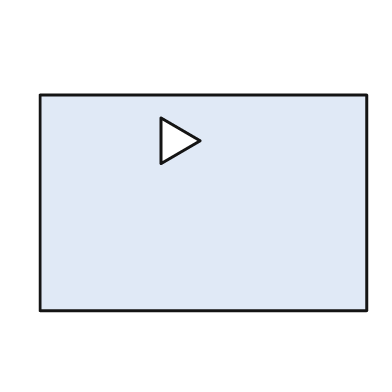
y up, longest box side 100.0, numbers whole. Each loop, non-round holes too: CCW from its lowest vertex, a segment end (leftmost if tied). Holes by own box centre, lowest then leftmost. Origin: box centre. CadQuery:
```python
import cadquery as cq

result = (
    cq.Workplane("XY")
    .moveTo(-50.0, -33.0)
    .lineTo(50.0, -33.0)
    .lineTo(50.0, 33.0)
    .lineTo(-50.0, 33.0)
    .close()
    .moveTo(-13.0, 12.0)
    .lineTo(-1.0, 19.0)
    .lineTo(-13.0, 26.0)
    .close()
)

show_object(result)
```